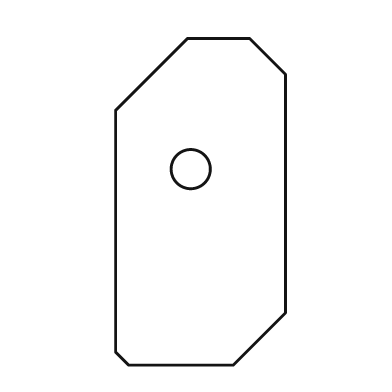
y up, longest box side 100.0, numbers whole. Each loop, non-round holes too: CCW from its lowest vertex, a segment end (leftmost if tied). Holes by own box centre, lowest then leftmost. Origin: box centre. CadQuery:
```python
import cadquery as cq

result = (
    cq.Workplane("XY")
    .moveTo(-22.0, -50.0)
    .lineTo(10.0, -50.0)
    .lineTo(26.0, -34.0)
    .lineTo(26.0, 39.0)
    .lineTo(15.0, 50.0)
    .lineTo(-4.0, 50.0)
    .lineTo(-26.0, 28.0)
    .lineTo(-26.0, -46.0)
    .close()
    .moveTo(-3.0, 10.0)
    .circle(6.0)
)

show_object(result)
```